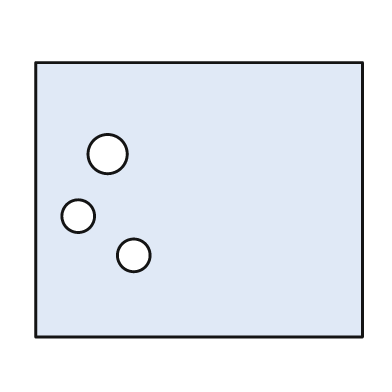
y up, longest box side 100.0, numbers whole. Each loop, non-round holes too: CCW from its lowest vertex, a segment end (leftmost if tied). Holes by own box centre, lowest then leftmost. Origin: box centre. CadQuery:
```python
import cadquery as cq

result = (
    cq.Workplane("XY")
    .moveTo(-50.0, -42.0)
    .lineTo(50.0, -42.0)
    .lineTo(50.0, 42.0)
    .lineTo(-50.0, 42.0)
    .close()
    .moveTo(-20.0, -17.0)
    .circle(5.0)
    .moveTo(-37.0, -5.0)
    .circle(5.0)
    .moveTo(-28.0, 14.0)
    .circle(6.0)
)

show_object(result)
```